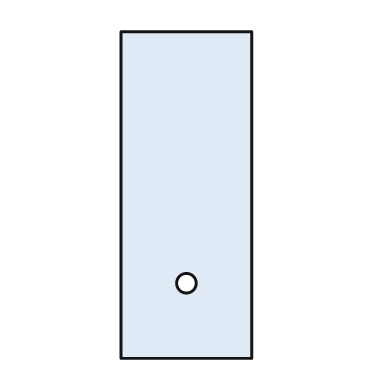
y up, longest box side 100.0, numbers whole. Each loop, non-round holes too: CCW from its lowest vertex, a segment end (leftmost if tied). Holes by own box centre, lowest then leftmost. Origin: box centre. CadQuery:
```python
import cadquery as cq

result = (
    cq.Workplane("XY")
    .moveTo(-20.0, -50.0)
    .lineTo(20.0, -50.0)
    .lineTo(20.0, 50.0)
    .lineTo(-20.0, 50.0)
    .close()
    .moveTo(0.0, -27.0)
    .circle(3.0)
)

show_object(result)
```